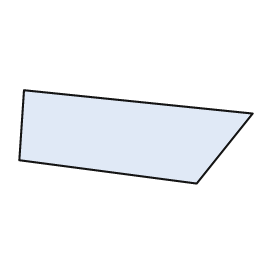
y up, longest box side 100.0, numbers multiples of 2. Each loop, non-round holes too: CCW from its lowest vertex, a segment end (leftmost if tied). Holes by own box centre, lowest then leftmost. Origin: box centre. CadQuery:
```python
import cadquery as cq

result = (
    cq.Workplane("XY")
    .moveTo(26.0, -20.0)
    .lineTo(50.0, 10.0)
    .lineTo(-48.0, 20.0)
    .lineTo(-50.0, -10.0)
    .close()
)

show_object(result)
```